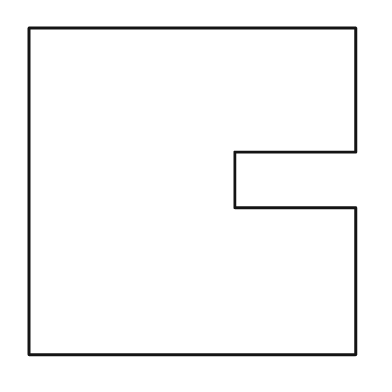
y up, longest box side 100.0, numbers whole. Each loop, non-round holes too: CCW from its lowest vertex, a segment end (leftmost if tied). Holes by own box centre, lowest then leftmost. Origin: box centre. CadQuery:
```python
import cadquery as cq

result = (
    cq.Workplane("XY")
    .moveTo(-50.0, -50.0)
    .lineTo(50.0, -50.0)
    .lineTo(50.0, -5.0)
    .lineTo(13.0, -5.0)
    .lineTo(13.0, 12.0)
    .lineTo(50.0, 12.0)
    .lineTo(50.0, 50.0)
    .lineTo(-50.0, 50.0)
    .close()
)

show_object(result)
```